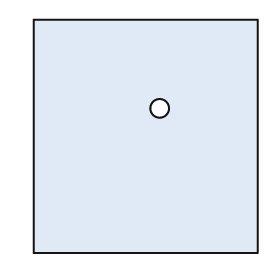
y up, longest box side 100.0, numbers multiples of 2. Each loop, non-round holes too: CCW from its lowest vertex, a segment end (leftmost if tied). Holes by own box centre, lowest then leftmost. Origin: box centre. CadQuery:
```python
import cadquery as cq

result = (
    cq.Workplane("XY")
    .moveTo(-48.0, -50.0)
    .lineTo(48.0, -50.0)
    .lineTo(48.0, 50.0)
    .lineTo(-48.0, 50.0)
    .close()
    .moveTo(6.0, 12.0)
    .circle(4.0)
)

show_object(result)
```